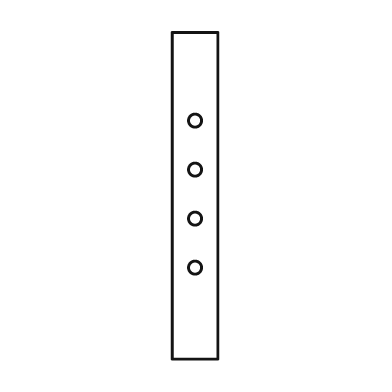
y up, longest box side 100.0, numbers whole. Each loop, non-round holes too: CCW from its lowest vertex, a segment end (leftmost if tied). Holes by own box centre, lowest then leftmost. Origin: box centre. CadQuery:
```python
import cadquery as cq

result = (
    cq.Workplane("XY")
    .moveTo(-7.0, -50.0)
    .lineTo(7.0, -50.0)
    .lineTo(7.0, 50.0)
    .lineTo(-7.0, 50.0)
    .close()
    .moveTo(0.0, -22.0)
    .circle(2.0)
    .moveTo(0.0, -7.0)
    .circle(2.0)
    .moveTo(0.0, 8.0)
    .circle(2.0)
    .moveTo(0.0, 23.0)
    .circle(2.0)
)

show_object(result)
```